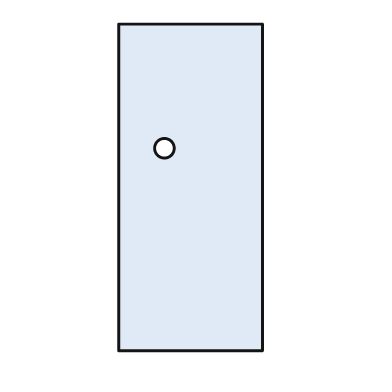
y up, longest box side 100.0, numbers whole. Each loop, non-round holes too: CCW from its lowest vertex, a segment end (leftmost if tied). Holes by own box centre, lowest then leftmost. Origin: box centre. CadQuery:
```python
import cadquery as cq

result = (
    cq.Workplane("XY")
    .moveTo(-22.0, -50.0)
    .lineTo(22.0, -50.0)
    .lineTo(22.0, 50.0)
    .lineTo(-22.0, 50.0)
    .close()
    .moveTo(-8.0, 12.0)
    .circle(3.0)
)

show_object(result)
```